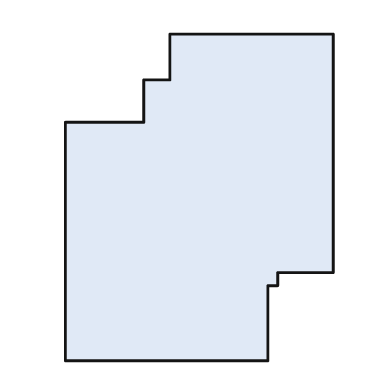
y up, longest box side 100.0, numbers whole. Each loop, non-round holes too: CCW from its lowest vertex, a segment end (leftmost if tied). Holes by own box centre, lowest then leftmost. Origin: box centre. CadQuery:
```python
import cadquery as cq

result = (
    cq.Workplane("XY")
    .moveTo(-41.0, -50.0)
    .lineTo(21.0, -50.0)
    .lineTo(21.0, -27.0)
    .lineTo(24.0, -27.0)
    .lineTo(24.0, -23.0)
    .lineTo(41.0, -23.0)
    .lineTo(41.0, 50.0)
    .lineTo(-9.0, 50.0)
    .lineTo(-9.0, 36.0)
    .lineTo(-17.0, 36.0)
    .lineTo(-17.0, 23.0)
    .lineTo(-41.0, 23.0)
    .close()
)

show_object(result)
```